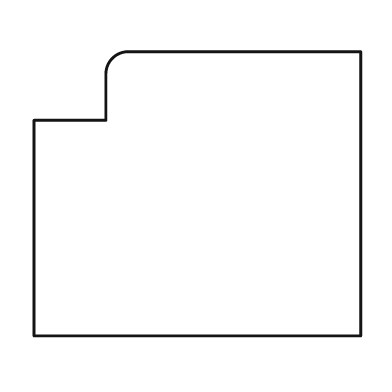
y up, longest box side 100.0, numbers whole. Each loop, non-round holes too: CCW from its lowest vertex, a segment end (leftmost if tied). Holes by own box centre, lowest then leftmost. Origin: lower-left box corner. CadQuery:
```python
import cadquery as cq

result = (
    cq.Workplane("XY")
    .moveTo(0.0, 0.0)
    .lineTo(100.0, 0.0)
    .lineTo(100.0, 87.0)
    .lineTo(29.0, 87.0)
    .threePointArc((24.0, 85.0), (22.0, 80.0))
    .lineTo(22.0, 66.0)
    .lineTo(0.0, 66.0)
    .close()
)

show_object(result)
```